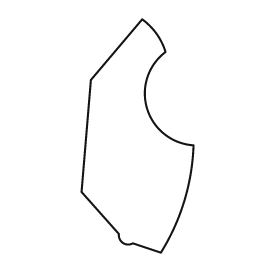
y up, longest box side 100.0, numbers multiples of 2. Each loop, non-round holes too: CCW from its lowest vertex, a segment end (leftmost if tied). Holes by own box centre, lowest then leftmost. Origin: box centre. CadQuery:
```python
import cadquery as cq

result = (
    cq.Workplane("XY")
    .moveTo(10.0, -50.0)
    .threePointArc((20.0, -28.0), (24.0, -4.0))
    .threePointArc((4.0, 12.0), (12.0, 36.0))
    .threePointArc((8.0, 44.0), (2.0, 50.0))
    .lineTo(-20.0, 24.0)
    .lineTo(-24.0, -24.0)
    .lineTo(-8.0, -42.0)
    .threePointArc((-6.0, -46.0), (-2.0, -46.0))
    .close()
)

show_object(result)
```